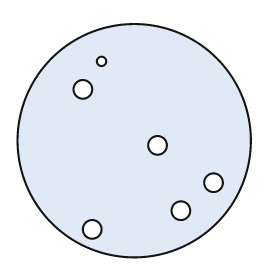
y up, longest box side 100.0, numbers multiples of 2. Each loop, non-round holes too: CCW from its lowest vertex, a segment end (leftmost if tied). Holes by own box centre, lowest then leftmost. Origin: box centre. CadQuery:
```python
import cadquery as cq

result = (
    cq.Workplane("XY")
    .moveTo(0.0, 0.0)
    .circle(50.0)
    .moveTo(-18.0, -38.0)
    .circle(4.0)
    .moveTo(20.0, -30.0)
    .circle(4.0)
    .moveTo(34.0, -18.0)
    .circle(4.0)
    .moveTo(10.0, -2.0)
    .circle(4.0)
    .moveTo(-22.0, 22.0)
    .circle(4.0)
    .moveTo(-14.0, 34.0)
    .circle(2.0)
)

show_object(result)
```